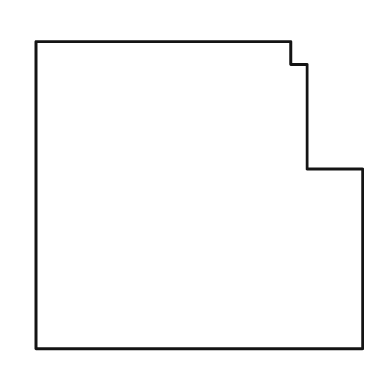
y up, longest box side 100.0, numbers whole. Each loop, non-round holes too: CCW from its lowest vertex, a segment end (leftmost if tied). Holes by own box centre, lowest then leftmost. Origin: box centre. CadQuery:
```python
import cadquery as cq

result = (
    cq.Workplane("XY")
    .moveTo(-50.0, -47.0)
    .lineTo(50.0, -47.0)
    .lineTo(50.0, 8.0)
    .lineTo(33.0, 8.0)
    .lineTo(33.0, 40.0)
    .lineTo(28.0, 40.0)
    .lineTo(28.0, 47.0)
    .lineTo(-50.0, 47.0)
    .close()
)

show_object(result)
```